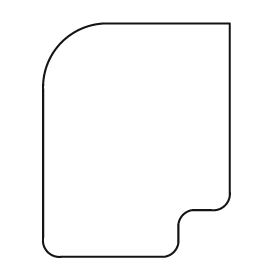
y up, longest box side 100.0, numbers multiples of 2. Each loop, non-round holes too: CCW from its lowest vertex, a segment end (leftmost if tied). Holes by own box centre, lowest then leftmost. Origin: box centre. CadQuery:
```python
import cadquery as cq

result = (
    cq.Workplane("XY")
    .moveTo(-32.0, -50.0)
    .lineTo(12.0, -50.0)
    .threePointArc((16.0, -48.0), (18.0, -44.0))
    .lineTo(18.0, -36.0)
    .threePointArc((20.0, -32.0), (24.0, -30.0))
    .lineTo(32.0, -30.0)
    .threePointArc((38.0, -28.0), (40.0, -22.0))
    .lineTo(40.0, 50.0)
    .lineTo(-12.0, 50.0)
    .threePointArc((-32.0, 42.0), (-40.0, 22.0))
    .lineTo(-40.0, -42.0)
    .threePointArc((-38.0, -48.0), (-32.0, -50.0))
    .close()
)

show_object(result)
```